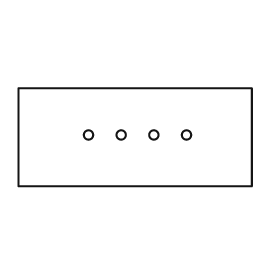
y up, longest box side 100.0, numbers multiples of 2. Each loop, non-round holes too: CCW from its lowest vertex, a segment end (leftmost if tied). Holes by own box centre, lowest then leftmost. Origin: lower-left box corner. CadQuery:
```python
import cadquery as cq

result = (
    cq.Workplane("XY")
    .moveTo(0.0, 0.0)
    .lineTo(100.0, 0.0)
    .lineTo(100.0, 42.0)
    .lineTo(0.0, 42.0)
    .close()
    .moveTo(30.0, 22.0)
    .circle(2.0)
    .moveTo(44.0, 22.0)
    .circle(2.0)
    .moveTo(58.0, 22.0)
    .circle(2.0)
    .moveTo(72.0, 22.0)
    .circle(2.0)
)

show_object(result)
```